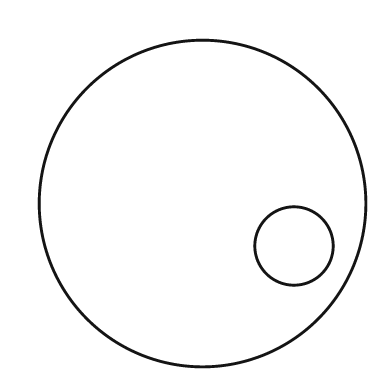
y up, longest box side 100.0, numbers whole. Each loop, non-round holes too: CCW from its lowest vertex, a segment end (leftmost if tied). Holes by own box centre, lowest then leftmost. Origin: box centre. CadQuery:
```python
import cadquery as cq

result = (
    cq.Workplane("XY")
    .moveTo(0.0, 0.0)
    .circle(50.0)
    .moveTo(28.0, -13.0)
    .circle(12.0)
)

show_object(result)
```